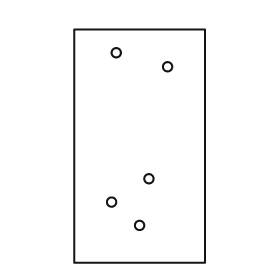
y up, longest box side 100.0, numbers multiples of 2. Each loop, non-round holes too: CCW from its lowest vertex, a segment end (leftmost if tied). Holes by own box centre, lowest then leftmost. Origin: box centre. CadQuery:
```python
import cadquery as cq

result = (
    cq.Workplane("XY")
    .moveTo(-28.0, -50.0)
    .lineTo(28.0, -50.0)
    .lineTo(28.0, 50.0)
    .lineTo(-28.0, 50.0)
    .close()
    .moveTo(0.0, -34.0)
    .circle(2.0)
    .moveTo(-12.0, -24.0)
    .circle(2.0)
    .moveTo(4.0, -14.0)
    .circle(2.0)
    .moveTo(12.0, 34.0)
    .circle(2.0)
    .moveTo(-10.0, 40.0)
    .circle(2.0)
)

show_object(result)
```